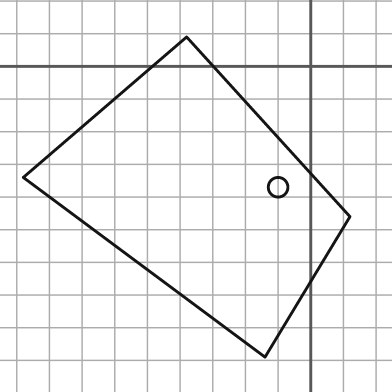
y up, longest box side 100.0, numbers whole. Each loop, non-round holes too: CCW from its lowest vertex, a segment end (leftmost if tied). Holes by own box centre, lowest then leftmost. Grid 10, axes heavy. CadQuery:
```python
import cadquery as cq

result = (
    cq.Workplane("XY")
    .moveTo(-14.0, -89.0)
    .lineTo(12.0, -46.0)
    .lineTo(-38.0, 9.0)
    .lineTo(-88.0, -34.0)
    .close()
    .moveTo(-10.0, -37.0)
    .circle(3.0)
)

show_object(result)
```